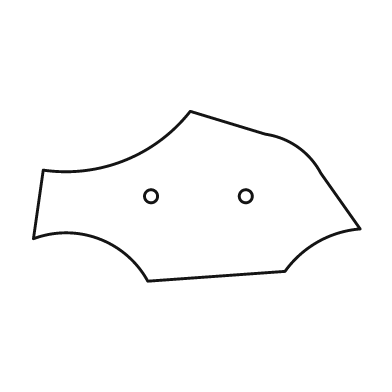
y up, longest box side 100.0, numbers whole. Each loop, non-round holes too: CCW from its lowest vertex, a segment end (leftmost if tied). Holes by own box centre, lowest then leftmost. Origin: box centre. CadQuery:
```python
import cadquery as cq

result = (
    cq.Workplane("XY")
    .moveTo(-15.0, -26.0)
    .lineTo(27.0, -23.0)
    .threePointArc((37.0, -14.0), (50.0, -10.0))
    .lineTo(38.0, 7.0)
    .threePointArc((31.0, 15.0), (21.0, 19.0))
    .lineTo(-2.0, 26.0)
    .threePointArc((-22.0, 11.0), (-47.0, 8.0))
    .lineTo(-50.0, -13.0)
    .threePointArc((-30.0, -13.0), (-15.0, -26.0))
    .close()
    .moveTo(-14.0, 0.0)
    .circle(2.0)
    .moveTo(15.0, 0.0)
    .circle(2.0)
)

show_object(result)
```